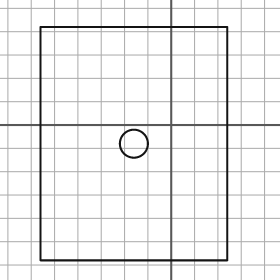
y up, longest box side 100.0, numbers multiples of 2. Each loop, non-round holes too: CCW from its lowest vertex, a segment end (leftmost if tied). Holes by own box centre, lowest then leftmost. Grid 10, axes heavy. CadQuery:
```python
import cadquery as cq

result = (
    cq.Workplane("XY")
    .moveTo(-56.0, -58.0)
    .lineTo(24.0, -58.0)
    .lineTo(24.0, 42.0)
    .lineTo(-56.0, 42.0)
    .close()
    .moveTo(-16.0, -8.0)
    .circle(6.0)
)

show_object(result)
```